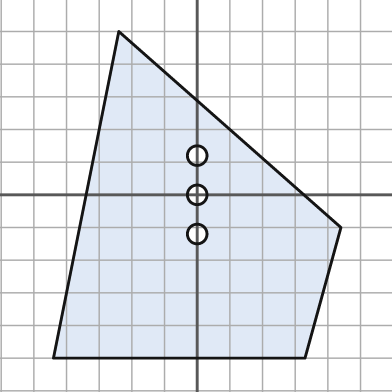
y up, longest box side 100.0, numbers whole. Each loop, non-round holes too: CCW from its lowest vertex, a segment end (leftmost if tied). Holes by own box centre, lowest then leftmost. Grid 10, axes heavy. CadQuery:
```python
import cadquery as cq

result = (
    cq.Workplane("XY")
    .moveTo(-44.0, -50.0)
    .lineTo(33.0, -50.0)
    .lineTo(44.0, -10.0)
    .lineTo(-24.0, 50.0)
    .close()
    .moveTo(0.0, -12.0)
    .circle(3.0)
    .moveTo(0.0, 0.0)
    .circle(3.0)
    .moveTo(0.0, 12.0)
    .circle(3.0)
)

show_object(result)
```